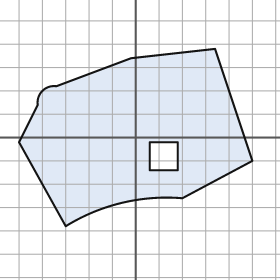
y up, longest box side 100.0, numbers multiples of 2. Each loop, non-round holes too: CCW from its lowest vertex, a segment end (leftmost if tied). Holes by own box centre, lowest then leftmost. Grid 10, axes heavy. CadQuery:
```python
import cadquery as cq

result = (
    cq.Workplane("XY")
    .moveTo(-30.0, -38.0)
    .threePointArc((-6.0, -28.0), (20.0, -26.0))
    .lineTo(50.0, -10.0)
    .lineTo(34.0, 38.0)
    .lineTo(-2.0, 34.0)
    .lineTo(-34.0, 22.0)
    .threePointArc((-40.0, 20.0), (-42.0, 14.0))
    .lineTo(-50.0, -2.0)
    .close()
    .moveTo(6.0, -14.0)
    .lineTo(18.0, -14.0)
    .lineTo(18.0, -2.0)
    .lineTo(6.0, -2.0)
    .close()
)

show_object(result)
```